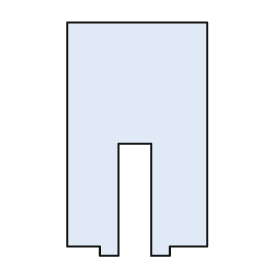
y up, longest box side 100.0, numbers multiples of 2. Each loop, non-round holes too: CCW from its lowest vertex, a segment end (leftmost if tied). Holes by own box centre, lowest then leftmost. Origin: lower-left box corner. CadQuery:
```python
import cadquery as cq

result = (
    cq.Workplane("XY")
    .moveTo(14.0, 0.0)
    .lineTo(22.0, 0.0)
    .lineTo(22.0, 48.0)
    .lineTo(36.0, 48.0)
    .lineTo(36.0, 0.0)
    .lineTo(44.0, 0.0)
    .lineTo(44.0, 4.0)
    .lineTo(60.0, 4.0)
    .lineTo(60.0, 100.0)
    .lineTo(0.0, 100.0)
    .lineTo(0.0, 4.0)
    .lineTo(14.0, 4.0)
    .close()
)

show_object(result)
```